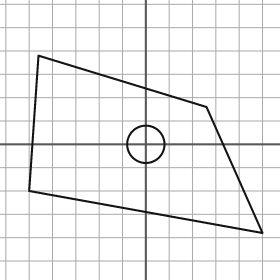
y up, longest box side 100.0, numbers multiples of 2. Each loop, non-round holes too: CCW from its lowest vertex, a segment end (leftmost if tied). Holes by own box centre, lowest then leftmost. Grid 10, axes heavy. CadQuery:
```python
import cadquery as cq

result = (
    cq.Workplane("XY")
    .moveTo(50.0, -38.0)
    .lineTo(26.0, 16.0)
    .lineTo(-46.0, 38.0)
    .lineTo(-50.0, -20.0)
    .close()
    .moveTo(0.0, 0.0)
    .circle(8.0)
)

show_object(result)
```